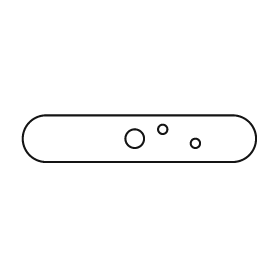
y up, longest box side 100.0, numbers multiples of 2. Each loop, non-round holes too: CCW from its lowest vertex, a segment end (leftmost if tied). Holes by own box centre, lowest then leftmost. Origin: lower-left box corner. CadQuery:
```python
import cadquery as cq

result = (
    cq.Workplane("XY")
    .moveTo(10.0, 0.0)
    .lineTo(90.0, 0.0)
    .threePointArc((100.0, 10.0), (90.0, 20.0))
    .lineTo(10.0, 20.0)
    .threePointArc((0.0, 10.0), (10.0, 0.0))
    .close()
    .moveTo(74.0, 8.0)
    .circle(2.0)
    .moveTo(48.0, 10.0)
    .circle(4.0)
    .moveTo(60.0, 14.0)
    .circle(2.0)
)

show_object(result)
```